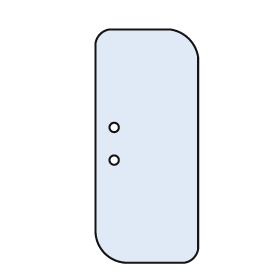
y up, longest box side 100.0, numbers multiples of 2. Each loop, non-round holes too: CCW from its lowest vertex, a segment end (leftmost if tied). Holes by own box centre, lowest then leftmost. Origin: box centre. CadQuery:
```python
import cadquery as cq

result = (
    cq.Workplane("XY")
    .moveTo(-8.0, -50.0)
    .lineTo(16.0, -50.0)
    .threePointArc((20.0, -48.0), (22.0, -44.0))
    .lineTo(22.0, 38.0)
    .threePointArc((18.0, 46.0), (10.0, 50.0))
    .lineTo(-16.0, 50.0)
    .threePointArc((-20.0, 48.0), (-22.0, 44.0))
    .lineTo(-22.0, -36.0)
    .threePointArc((-18.0, -46.0), (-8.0, -50.0))
    .close()
    .moveTo(-14.0, -6.0)
    .circle(2.0)
    .moveTo(-14.0, 8.0)
    .circle(2.0)
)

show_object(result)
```